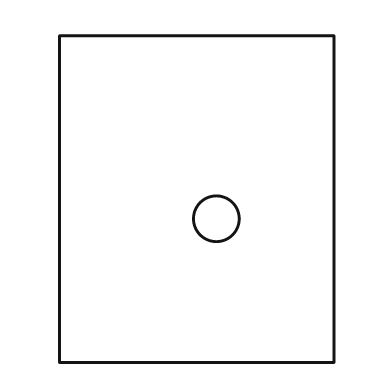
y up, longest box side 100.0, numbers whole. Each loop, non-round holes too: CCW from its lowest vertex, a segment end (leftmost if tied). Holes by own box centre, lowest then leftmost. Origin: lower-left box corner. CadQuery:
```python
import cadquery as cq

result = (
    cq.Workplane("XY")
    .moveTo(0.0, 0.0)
    .lineTo(84.0, 0.0)
    .lineTo(84.0, 100.0)
    .lineTo(0.0, 100.0)
    .close()
    .moveTo(48.0, 44.0)
    .circle(7.0)
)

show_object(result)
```